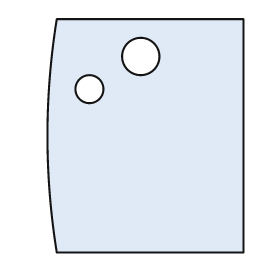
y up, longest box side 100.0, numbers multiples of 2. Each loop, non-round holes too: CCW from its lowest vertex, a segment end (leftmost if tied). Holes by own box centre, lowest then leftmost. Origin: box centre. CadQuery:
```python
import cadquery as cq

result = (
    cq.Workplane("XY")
    .moveTo(-38.0, -50.0)
    .lineTo(42.0, -50.0)
    .lineTo(42.0, 50.0)
    .lineTo(-38.0, 50.0)
    .threePointArc((-42.0, 0.0), (-38.0, -50.0))
    .close()
    .moveTo(-24.0, 20.0)
    .circle(6.0)
    .moveTo(-2.0, 34.0)
    .circle(8.0)
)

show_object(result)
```